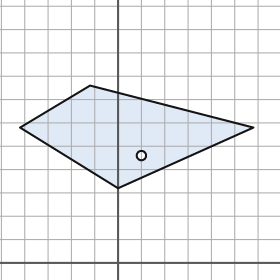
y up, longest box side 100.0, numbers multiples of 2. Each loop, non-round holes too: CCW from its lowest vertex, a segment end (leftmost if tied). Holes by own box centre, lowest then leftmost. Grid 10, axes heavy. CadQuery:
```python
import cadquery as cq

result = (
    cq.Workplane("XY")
    .moveTo(0.0, 32.0)
    .lineTo(58.0, 58.0)
    .lineTo(-12.0, 76.0)
    .lineTo(-42.0, 58.0)
    .close()
    .moveTo(10.0, 46.0)
    .circle(2.0)
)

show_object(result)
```